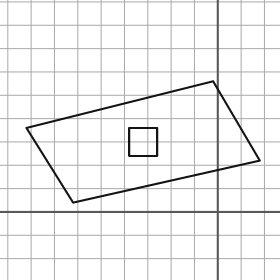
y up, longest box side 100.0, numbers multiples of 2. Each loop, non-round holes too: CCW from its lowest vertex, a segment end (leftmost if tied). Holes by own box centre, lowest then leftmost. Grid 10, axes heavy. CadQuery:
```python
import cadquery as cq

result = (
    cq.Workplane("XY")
    .moveTo(-62.0, 4.0)
    .lineTo(18.0, 22.0)
    .lineTo(-2.0, 56.0)
    .lineTo(-82.0, 36.0)
    .close()
    .moveTo(-38.0, 24.0)
    .lineTo(-26.0, 24.0)
    .lineTo(-26.0, 36.0)
    .lineTo(-38.0, 36.0)
    .close()
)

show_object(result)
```